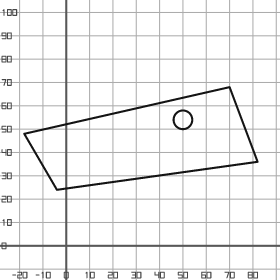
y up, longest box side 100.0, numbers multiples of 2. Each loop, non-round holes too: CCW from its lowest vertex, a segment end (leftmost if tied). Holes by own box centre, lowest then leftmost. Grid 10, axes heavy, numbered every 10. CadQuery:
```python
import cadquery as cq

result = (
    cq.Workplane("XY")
    .moveTo(-4.0, 24.0)
    .lineTo(82.0, 36.0)
    .lineTo(70.0, 68.0)
    .lineTo(-18.0, 48.0)
    .close()
    .moveTo(50.0, 54.0)
    .circle(4.0)
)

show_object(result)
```